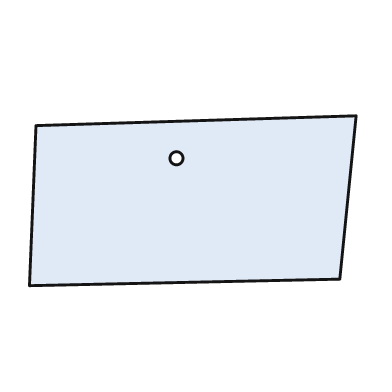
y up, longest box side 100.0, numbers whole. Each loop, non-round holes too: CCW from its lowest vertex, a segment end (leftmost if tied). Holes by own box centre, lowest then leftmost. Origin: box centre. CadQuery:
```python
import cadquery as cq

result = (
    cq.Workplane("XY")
    .moveTo(-50.0, -26.0)
    .lineTo(45.0, -24.0)
    .lineTo(50.0, 26.0)
    .lineTo(-48.0, 23.0)
    .close()
    .moveTo(-5.0, 13.0)
    .circle(2.0)
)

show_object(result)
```